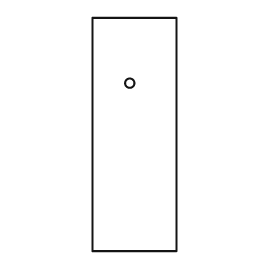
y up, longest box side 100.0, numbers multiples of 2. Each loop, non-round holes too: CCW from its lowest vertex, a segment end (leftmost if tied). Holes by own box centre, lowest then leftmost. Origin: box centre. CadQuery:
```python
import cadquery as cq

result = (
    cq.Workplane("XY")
    .moveTo(-18.0, -50.0)
    .lineTo(18.0, -50.0)
    .lineTo(18.0, 50.0)
    .lineTo(-18.0, 50.0)
    .close()
    .moveTo(-2.0, 22.0)
    .circle(2.0)
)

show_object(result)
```